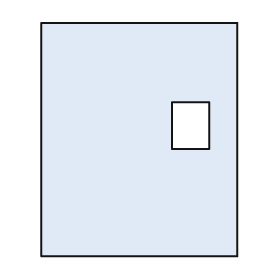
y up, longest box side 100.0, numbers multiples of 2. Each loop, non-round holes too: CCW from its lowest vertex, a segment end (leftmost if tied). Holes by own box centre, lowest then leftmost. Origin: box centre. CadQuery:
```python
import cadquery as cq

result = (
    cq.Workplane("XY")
    .moveTo(-42.0, -50.0)
    .lineTo(42.0, -50.0)
    .lineTo(42.0, 50.0)
    .lineTo(-42.0, 50.0)
    .close()
    .moveTo(14.0, -4.0)
    .lineTo(30.0, -4.0)
    .lineTo(30.0, 16.0)
    .lineTo(14.0, 16.0)
    .close()
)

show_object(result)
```